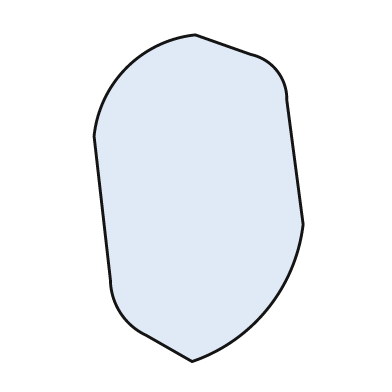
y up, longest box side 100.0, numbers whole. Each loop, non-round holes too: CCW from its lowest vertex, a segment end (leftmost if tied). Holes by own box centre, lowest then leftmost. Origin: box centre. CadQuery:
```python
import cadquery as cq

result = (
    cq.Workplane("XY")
    .moveTo(-2.0, -50.0)
    .threePointArc((21.0, -34.0), (32.0, -8.0))
    .lineTo(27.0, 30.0)
    .threePointArc((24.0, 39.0), (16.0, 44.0))
    .lineTo(-1.0, 50.0)
    .threePointArc((-22.0, 40.0), (-32.0, 19.0))
    .lineTo(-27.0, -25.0)
    .threePointArc((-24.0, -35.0), (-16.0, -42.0))
    .close()
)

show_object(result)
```